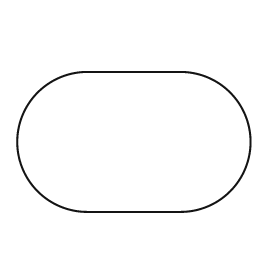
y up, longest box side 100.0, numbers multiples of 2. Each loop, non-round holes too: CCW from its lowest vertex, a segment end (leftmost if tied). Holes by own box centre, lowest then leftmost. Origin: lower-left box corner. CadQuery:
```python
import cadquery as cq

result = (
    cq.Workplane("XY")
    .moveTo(30.0, 0.0)
    .lineTo(70.0, 0.0)
    .threePointArc((100.0, 30.0), (70.0, 60.0))
    .lineTo(30.0, 60.0)
    .threePointArc((0.0, 30.0), (30.0, 0.0))
    .close()
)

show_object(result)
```